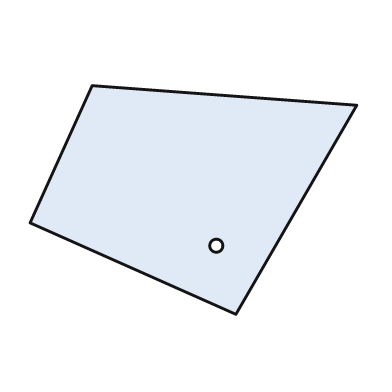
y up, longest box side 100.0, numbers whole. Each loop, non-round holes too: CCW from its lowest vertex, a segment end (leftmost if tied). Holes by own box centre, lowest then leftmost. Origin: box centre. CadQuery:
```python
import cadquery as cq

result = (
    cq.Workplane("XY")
    .moveTo(13.0, -35.0)
    .lineTo(50.0, 29.0)
    .lineTo(-31.0, 35.0)
    .lineTo(-50.0, -7.0)
    .close()
    .moveTo(7.0, -14.0)
    .circle(2.0)
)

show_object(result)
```